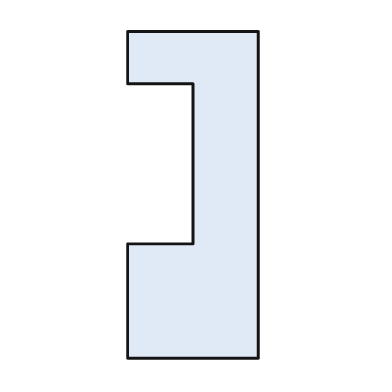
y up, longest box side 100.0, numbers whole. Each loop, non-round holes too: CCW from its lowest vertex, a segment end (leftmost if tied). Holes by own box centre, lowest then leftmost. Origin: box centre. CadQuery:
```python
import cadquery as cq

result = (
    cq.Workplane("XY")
    .moveTo(-20.0, -50.0)
    .lineTo(20.0, -50.0)
    .lineTo(20.0, 50.0)
    .lineTo(-20.0, 50.0)
    .lineTo(-20.0, 34.0)
    .lineTo(0.0, 34.0)
    .lineTo(0.0, -15.0)
    .lineTo(-20.0, -15.0)
    .close()
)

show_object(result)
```